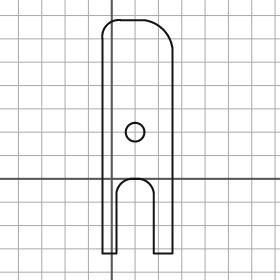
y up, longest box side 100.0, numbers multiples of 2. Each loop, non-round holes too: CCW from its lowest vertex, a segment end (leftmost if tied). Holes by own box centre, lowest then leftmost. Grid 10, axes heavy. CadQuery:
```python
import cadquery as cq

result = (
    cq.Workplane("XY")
    .moveTo(-4.0, -32.0)
    .lineTo(2.0, -32.0)
    .lineTo(2.0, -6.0)
    .threePointArc((4.0, -2.0), (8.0, 0.0))
    .lineTo(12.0, 0.0)
    .threePointArc((16.0, -2.0), (18.0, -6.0))
    .lineTo(18.0, -32.0)
    .lineTo(26.0, -32.0)
    .lineTo(26.0, 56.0)
    .threePointArc((22.0, 64.0), (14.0, 68.0))
    .lineTo(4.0, 68.0)
    .threePointArc((-2.0, 66.0), (-4.0, 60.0))
    .close()
    .moveTo(10.0, 20.0)
    .circle(4.0)
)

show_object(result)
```